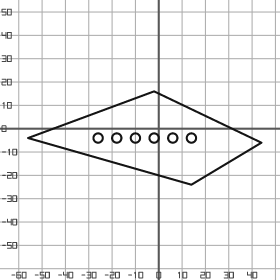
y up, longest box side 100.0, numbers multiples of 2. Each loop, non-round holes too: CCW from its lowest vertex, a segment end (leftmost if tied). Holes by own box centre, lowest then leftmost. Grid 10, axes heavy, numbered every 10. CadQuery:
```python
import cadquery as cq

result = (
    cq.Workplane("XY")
    .moveTo(14.0, -24.0)
    .lineTo(44.0, -6.0)
    .lineTo(-2.0, 16.0)
    .lineTo(-56.0, -4.0)
    .close()
    .moveTo(-26.0, -4.0)
    .circle(2.0)
    .moveTo(-18.0, -4.0)
    .circle(2.0)
    .moveTo(-10.0, -4.0)
    .circle(2.0)
    .moveTo(-2.0, -4.0)
    .circle(2.0)
    .moveTo(6.0, -4.0)
    .circle(2.0)
    .moveTo(14.0, -4.0)
    .circle(2.0)
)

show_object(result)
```